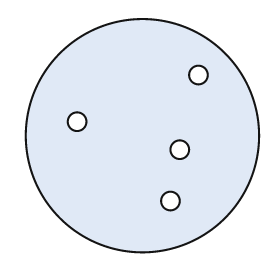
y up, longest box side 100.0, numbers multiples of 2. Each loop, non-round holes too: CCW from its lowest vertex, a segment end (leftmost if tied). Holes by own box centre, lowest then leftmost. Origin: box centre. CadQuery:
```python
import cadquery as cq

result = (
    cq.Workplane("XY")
    .moveTo(0.0, 0.0)
    .circle(50.0)
    .moveTo(12.0, -28.0)
    .circle(4.0)
    .moveTo(16.0, -6.0)
    .circle(4.0)
    .moveTo(-28.0, 6.0)
    .circle(4.0)
    .moveTo(24.0, 26.0)
    .circle(4.0)
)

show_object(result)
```